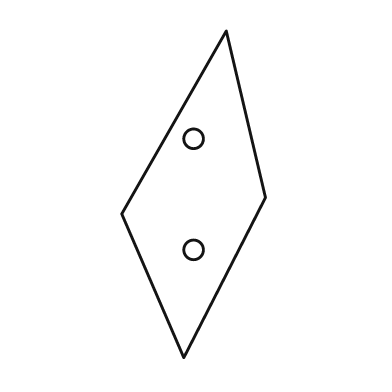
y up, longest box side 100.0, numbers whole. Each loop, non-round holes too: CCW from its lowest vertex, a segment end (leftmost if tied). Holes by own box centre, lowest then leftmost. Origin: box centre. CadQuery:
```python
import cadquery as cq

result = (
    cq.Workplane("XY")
    .moveTo(-3.0, -50.0)
    .lineTo(22.0, -1.0)
    .lineTo(10.0, 50.0)
    .lineTo(-22.0, -6.0)
    .close()
    .moveTo(0.0, -17.0)
    .circle(3.0)
    .moveTo(0.0, 17.0)
    .circle(3.0)
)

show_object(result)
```